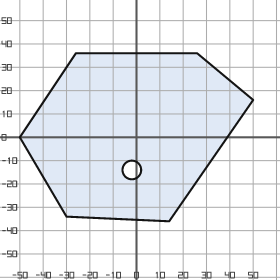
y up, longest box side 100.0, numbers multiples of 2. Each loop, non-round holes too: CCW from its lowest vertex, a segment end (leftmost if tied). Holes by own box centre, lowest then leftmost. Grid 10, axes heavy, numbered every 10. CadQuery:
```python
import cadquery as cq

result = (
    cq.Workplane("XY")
    .moveTo(14.0, -36.0)
    .lineTo(50.0, 16.0)
    .lineTo(26.0, 36.0)
    .lineTo(-26.0, 36.0)
    .lineTo(-50.0, 0.0)
    .lineTo(-30.0, -34.0)
    .close()
    .moveTo(-2.0, -14.0)
    .circle(4.0)
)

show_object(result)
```